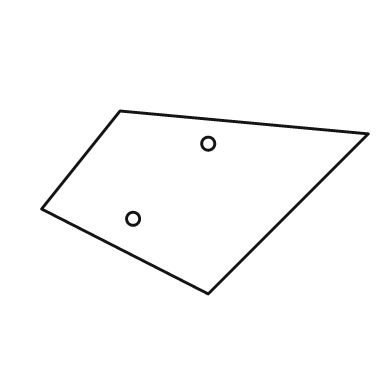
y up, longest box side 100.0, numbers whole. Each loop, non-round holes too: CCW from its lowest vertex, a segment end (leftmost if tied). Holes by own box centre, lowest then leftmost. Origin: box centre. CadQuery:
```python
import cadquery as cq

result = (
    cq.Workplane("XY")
    .moveTo(1.0, -28.0)
    .lineTo(50.0, 21.0)
    .lineTo(-26.0, 28.0)
    .lineTo(-50.0, -2.0)
    .close()
    .moveTo(-22.0, -5.0)
    .circle(2.0)
    .moveTo(1.0, 18.0)
    .circle(2.0)
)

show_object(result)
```